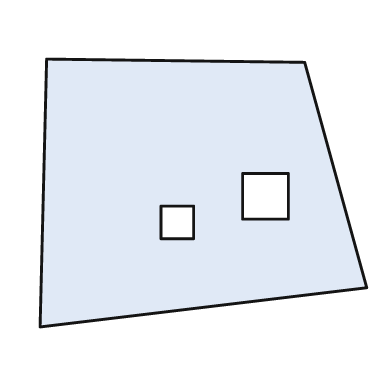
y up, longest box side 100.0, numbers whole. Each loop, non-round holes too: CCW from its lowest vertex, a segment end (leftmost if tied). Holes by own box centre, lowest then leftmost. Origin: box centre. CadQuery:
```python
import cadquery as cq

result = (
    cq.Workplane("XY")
    .moveTo(-50.0, -41.0)
    .lineTo(50.0, -29.0)
    .lineTo(31.0, 40.0)
    .lineTo(-48.0, 41.0)
    .close()
    .moveTo(-13.0, -14.0)
    .lineTo(-3.0, -14.0)
    .lineTo(-3.0, -4.0)
    .lineTo(-13.0, -4.0)
    .close()
    .moveTo(12.0, -8.0)
    .lineTo(26.0, -8.0)
    .lineTo(26.0, 6.0)
    .lineTo(12.0, 6.0)
    .close()
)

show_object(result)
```